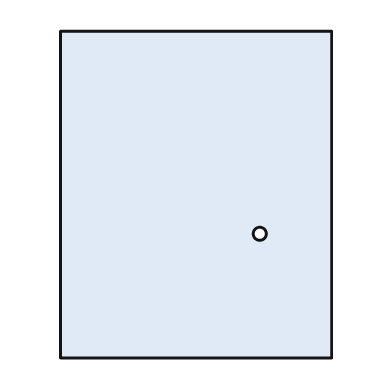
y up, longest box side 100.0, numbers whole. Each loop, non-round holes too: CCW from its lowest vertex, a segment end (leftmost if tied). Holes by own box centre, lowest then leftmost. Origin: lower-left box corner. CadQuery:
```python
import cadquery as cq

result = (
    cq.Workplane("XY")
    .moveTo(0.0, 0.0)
    .lineTo(83.0, 0.0)
    .lineTo(83.0, 100.0)
    .lineTo(0.0, 100.0)
    .close()
    .moveTo(61.0, 38.0)
    .circle(2.0)
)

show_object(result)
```